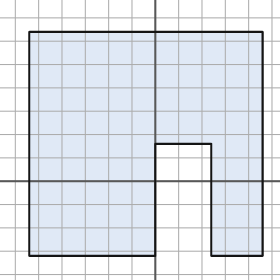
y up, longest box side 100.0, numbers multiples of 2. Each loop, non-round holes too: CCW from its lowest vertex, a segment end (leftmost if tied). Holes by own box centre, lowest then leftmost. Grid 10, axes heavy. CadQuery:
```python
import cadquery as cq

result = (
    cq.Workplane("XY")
    .moveTo(-54.0, -32.0)
    .lineTo(0.0, -32.0)
    .lineTo(0.0, 16.0)
    .lineTo(24.0, 16.0)
    .lineTo(24.0, -32.0)
    .lineTo(46.0, -32.0)
    .lineTo(46.0, 64.0)
    .lineTo(-54.0, 64.0)
    .close()
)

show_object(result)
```